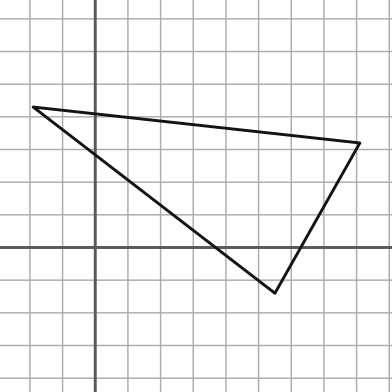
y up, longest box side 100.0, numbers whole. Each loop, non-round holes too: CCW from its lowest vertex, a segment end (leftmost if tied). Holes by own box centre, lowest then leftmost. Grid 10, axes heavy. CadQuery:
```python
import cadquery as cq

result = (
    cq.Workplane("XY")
    .moveTo(55.0, -14.0)
    .lineTo(81.0, 32.0)
    .lineTo(-19.0, 43.0)
    .close()
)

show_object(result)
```